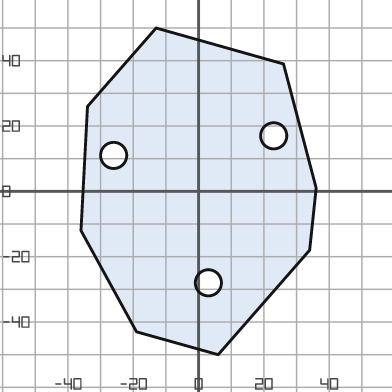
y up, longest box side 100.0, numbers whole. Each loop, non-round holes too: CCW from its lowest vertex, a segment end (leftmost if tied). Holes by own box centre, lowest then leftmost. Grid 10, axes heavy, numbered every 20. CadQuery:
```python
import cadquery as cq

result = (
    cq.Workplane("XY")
    .moveTo(6.0, -50.0)
    .lineTo(34.0, -18.0)
    .lineTo(36.0, 1.0)
    .lineTo(26.0, 39.0)
    .lineTo(-13.0, 50.0)
    .lineTo(-34.0, 26.0)
    .lineTo(-36.0, -12.0)
    .lineTo(-19.0, -43.0)
    .close()
    .moveTo(3.0, -28.0)
    .circle(4.0)
    .moveTo(-26.0, 11.0)
    .circle(4.0)
    .moveTo(23.0, 17.0)
    .circle(4.0)
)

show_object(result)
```